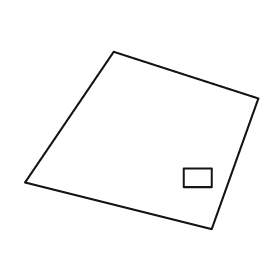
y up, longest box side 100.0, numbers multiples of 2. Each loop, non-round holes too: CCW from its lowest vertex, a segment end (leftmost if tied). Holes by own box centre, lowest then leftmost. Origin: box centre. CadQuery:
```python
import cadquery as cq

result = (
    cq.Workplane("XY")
    .moveTo(30.0, -38.0)
    .lineTo(50.0, 18.0)
    .lineTo(-12.0, 38.0)
    .lineTo(-50.0, -18.0)
    .close()
    .moveTo(18.0, -20.0)
    .lineTo(30.0, -20.0)
    .lineTo(30.0, -12.0)
    .lineTo(18.0, -12.0)
    .close()
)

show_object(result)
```